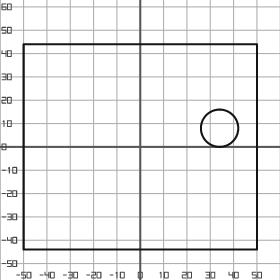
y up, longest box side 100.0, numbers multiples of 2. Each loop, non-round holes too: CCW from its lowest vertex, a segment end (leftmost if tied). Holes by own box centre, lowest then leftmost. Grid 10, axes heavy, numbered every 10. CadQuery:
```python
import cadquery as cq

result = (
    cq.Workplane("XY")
    .moveTo(-50.0, -44.0)
    .lineTo(50.0, -44.0)
    .lineTo(50.0, 44.0)
    .lineTo(-50.0, 44.0)
    .close()
    .moveTo(34.0, 8.0)
    .circle(8.0)
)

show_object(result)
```